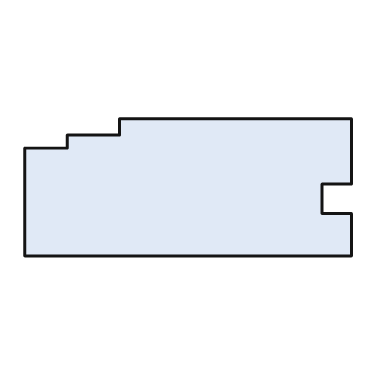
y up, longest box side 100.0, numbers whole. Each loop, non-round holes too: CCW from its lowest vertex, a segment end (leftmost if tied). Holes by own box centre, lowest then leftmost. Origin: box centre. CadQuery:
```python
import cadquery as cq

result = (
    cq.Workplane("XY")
    .moveTo(-50.0, -21.0)
    .lineTo(50.0, -21.0)
    .lineTo(50.0, -8.0)
    .lineTo(41.0, -8.0)
    .lineTo(41.0, 1.0)
    .lineTo(50.0, 1.0)
    .lineTo(50.0, 21.0)
    .lineTo(-21.0, 21.0)
    .lineTo(-21.0, 16.0)
    .lineTo(-37.0, 16.0)
    .lineTo(-37.0, 12.0)
    .lineTo(-50.0, 12.0)
    .close()
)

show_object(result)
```